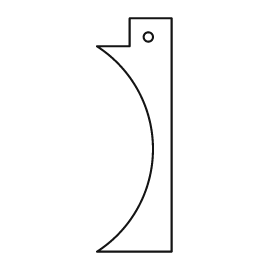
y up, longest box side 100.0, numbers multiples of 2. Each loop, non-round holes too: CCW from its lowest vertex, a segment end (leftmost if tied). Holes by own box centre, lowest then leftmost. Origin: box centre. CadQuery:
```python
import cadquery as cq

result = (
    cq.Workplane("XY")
    .moveTo(-16.0, -50.0)
    .lineTo(16.0, -50.0)
    .lineTo(16.0, 50.0)
    .lineTo(-2.0, 50.0)
    .lineTo(-2.0, 38.0)
    .lineTo(-16.0, 38.0)
    .threePointArc((8.0, -6.0), (-16.0, -50.0))
    .close()
    .moveTo(6.0, 42.0)
    .circle(2.0)
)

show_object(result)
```